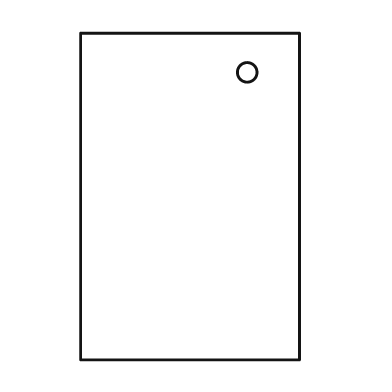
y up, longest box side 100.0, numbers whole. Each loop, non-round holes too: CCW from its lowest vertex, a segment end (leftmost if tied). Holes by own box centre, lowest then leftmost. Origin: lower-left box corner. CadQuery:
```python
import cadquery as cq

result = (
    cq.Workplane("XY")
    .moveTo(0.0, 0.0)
    .lineTo(67.0, 0.0)
    .lineTo(67.0, 100.0)
    .lineTo(0.0, 100.0)
    .close()
    .moveTo(51.0, 88.0)
    .circle(3.0)
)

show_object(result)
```